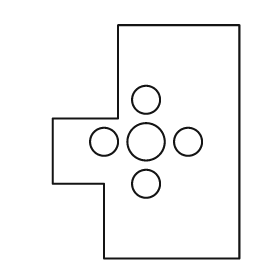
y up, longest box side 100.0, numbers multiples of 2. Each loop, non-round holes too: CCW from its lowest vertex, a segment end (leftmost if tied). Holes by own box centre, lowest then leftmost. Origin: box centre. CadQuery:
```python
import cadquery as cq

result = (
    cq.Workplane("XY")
    .moveTo(-18.0, -50.0)
    .lineTo(40.0, -50.0)
    .lineTo(40.0, 50.0)
    .lineTo(-12.0, 50.0)
    .lineTo(-12.0, 10.0)
    .lineTo(-40.0, 10.0)
    .lineTo(-40.0, -18.0)
    .lineTo(-18.0, -18.0)
    .close()
    .moveTo(0.0, -18.0)
    .circle(6.0)
    .moveTo(-18.0, 0.0)
    .circle(6.0)
    .moveTo(0.0, 0.0)
    .circle(8.0)
    .moveTo(18.0, 0.0)
    .circle(6.0)
    .moveTo(0.0, 18.0)
    .circle(6.0)
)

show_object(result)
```